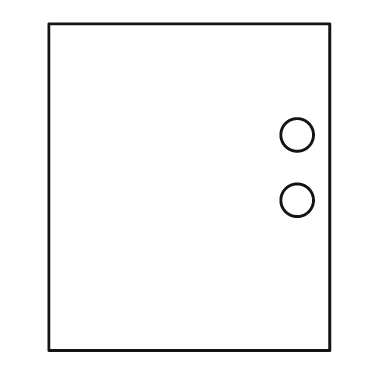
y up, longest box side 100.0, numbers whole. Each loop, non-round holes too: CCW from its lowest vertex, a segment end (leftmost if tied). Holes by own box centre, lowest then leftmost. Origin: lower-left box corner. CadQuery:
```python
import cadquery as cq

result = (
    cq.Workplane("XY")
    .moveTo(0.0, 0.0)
    .lineTo(86.0, 0.0)
    .lineTo(86.0, 100.0)
    .lineTo(0.0, 100.0)
    .close()
    .moveTo(76.0, 46.0)
    .circle(5.0)
    .moveTo(76.0, 66.0)
    .circle(5.0)
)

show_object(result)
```